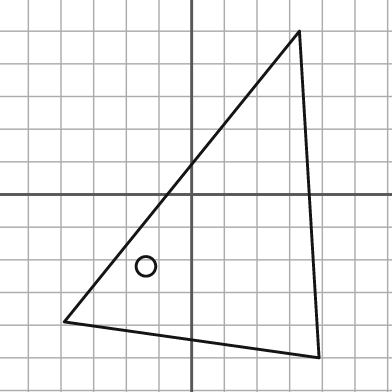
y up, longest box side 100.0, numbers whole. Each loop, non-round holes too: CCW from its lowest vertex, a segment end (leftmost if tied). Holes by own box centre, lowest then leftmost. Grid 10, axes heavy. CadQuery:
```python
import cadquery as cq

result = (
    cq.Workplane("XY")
    .moveTo(39.0, -50.0)
    .lineTo(33.0, 50.0)
    .lineTo(-39.0, -39.0)
    .close()
    .moveTo(-14.0, -22.0)
    .circle(3.0)
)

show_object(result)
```